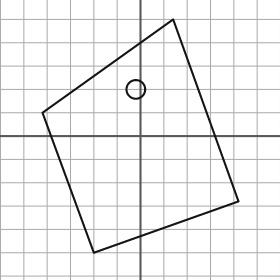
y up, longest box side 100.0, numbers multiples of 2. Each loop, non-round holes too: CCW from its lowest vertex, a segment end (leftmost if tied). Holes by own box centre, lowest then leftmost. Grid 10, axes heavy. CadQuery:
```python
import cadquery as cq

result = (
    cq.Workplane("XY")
    .moveTo(-20.0, -50.0)
    .lineTo(42.0, -28.0)
    .lineTo(14.0, 50.0)
    .lineTo(-42.0, 10.0)
    .close()
    .moveTo(-2.0, 20.0)
    .circle(4.0)
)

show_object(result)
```